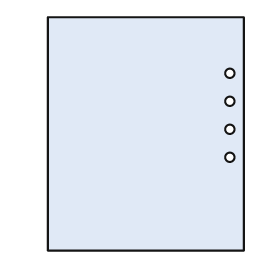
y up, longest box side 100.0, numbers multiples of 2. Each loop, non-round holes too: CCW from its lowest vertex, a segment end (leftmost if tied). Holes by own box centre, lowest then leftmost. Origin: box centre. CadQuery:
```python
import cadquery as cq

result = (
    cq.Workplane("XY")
    .moveTo(-42.0, -50.0)
    .lineTo(42.0, -50.0)
    .lineTo(42.0, 50.0)
    .lineTo(-42.0, 50.0)
    .close()
    .moveTo(36.0, -10.0)
    .circle(2.0)
    .moveTo(36.0, 2.0)
    .circle(2.0)
    .moveTo(36.0, 14.0)
    .circle(2.0)
    .moveTo(36.0, 26.0)
    .circle(2.0)
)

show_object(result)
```